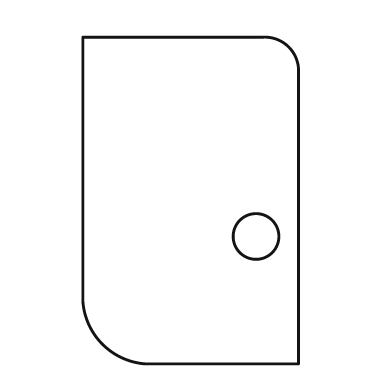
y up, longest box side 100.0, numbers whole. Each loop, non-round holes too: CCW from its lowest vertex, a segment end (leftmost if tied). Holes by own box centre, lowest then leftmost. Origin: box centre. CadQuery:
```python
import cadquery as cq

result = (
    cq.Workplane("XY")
    .moveTo(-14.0, -50.0)
    .lineTo(33.0, -50.0)
    .lineTo(33.0, 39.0)
    .threePointArc((30.0, 47.0), (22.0, 50.0))
    .lineTo(-33.0, 50.0)
    .lineTo(-33.0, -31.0)
    .threePointArc((-27.0, -44.0), (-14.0, -50.0))
    .close()
    .moveTo(20.0, -11.0)
    .circle(7.0)
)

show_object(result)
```